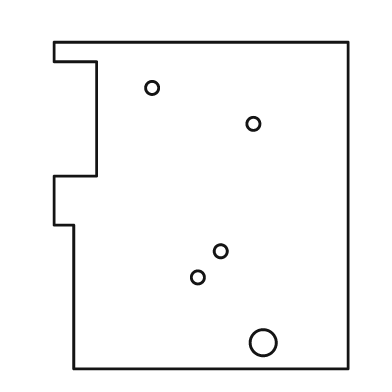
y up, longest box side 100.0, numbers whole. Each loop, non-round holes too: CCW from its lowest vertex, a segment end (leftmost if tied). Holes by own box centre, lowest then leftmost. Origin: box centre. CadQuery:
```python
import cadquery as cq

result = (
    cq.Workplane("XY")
    .moveTo(-39.0, -50.0)
    .lineTo(45.0, -50.0)
    .lineTo(45.0, 50.0)
    .lineTo(-45.0, 50.0)
    .lineTo(-45.0, 44.0)
    .lineTo(-32.0, 44.0)
    .lineTo(-32.0, 9.0)
    .lineTo(-45.0, 9.0)
    .lineTo(-45.0, -6.0)
    .lineTo(-39.0, -6.0)
    .close()
    .moveTo(19.0, -42.0)
    .circle(4.0)
    .moveTo(-1.0, -22.0)
    .circle(2.0)
    .moveTo(6.0, -14.0)
    .circle(2.0)
    .moveTo(16.0, 25.0)
    .circle(2.0)
    .moveTo(-15.0, 36.0)
    .circle(2.0)
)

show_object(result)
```